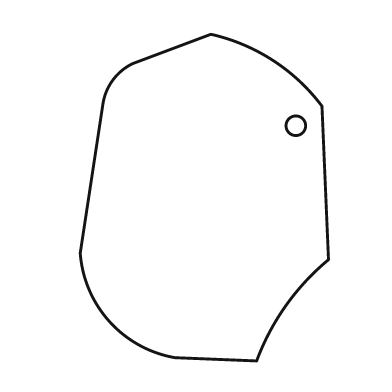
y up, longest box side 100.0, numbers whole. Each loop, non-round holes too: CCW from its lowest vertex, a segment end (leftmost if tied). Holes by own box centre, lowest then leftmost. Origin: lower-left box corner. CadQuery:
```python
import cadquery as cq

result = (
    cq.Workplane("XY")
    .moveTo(54.0, 0.0)
    .threePointArc((63.0, 17.0), (76.0, 31.0))
    .lineTo(74.0, 78.0)
    .threePointArc((59.0, 92.0), (40.0, 100.0))
    .lineTo(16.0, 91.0)
    .threePointArc((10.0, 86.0), (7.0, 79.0))
    .lineTo(0.0, 33.0)
    .threePointArc((9.0, 12.0), (29.0, 1.0))
    .close()
    .moveTo(66.0, 72.0)
    .circle(3.0)
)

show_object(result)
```